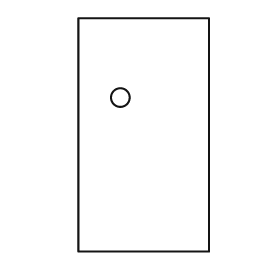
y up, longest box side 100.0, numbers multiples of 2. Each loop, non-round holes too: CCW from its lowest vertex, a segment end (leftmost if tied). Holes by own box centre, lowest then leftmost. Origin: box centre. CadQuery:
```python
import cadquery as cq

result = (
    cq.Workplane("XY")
    .moveTo(-28.0, -50.0)
    .lineTo(28.0, -50.0)
    .lineTo(28.0, 50.0)
    .lineTo(-28.0, 50.0)
    .close()
    .moveTo(-10.0, 16.0)
    .circle(4.0)
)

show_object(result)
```